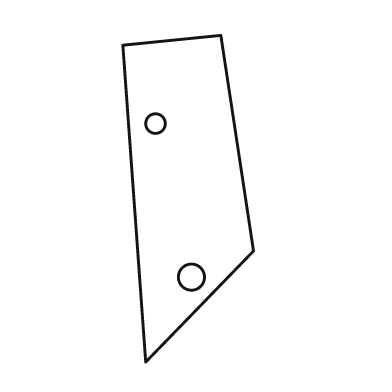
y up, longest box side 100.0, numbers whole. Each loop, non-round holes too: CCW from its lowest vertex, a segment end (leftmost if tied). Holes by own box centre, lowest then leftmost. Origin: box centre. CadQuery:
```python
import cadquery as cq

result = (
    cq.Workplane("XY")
    .moveTo(-13.0, -50.0)
    .lineTo(20.0, -16.0)
    .lineTo(10.0, 50.0)
    .lineTo(-20.0, 47.0)
    .close()
    .moveTo(1.0, -24.0)
    .circle(4.0)
    .moveTo(-10.0, 23.0)
    .circle(3.0)
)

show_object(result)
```